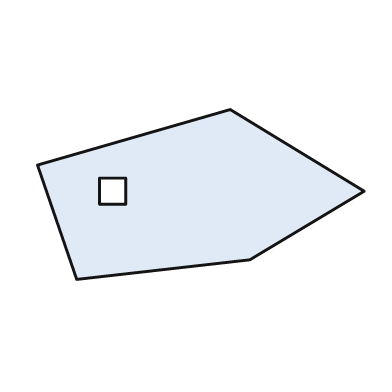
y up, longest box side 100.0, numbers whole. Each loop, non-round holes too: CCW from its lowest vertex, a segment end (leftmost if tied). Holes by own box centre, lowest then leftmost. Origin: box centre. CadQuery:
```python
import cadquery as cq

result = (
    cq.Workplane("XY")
    .moveTo(-38.0, -26.0)
    .lineTo(15.0, -20.0)
    .lineTo(50.0, 1.0)
    .lineTo(9.0, 26.0)
    .lineTo(-50.0, 9.0)
    .close()
    .moveTo(-31.0, -3.0)
    .lineTo(-23.0, -3.0)
    .lineTo(-23.0, 5.0)
    .lineTo(-31.0, 5.0)
    .close()
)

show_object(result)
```